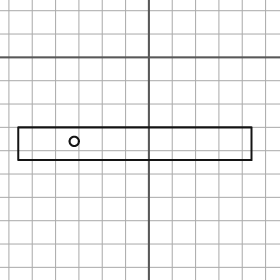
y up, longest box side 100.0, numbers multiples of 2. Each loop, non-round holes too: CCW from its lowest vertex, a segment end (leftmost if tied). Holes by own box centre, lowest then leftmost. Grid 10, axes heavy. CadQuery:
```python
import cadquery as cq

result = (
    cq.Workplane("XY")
    .moveTo(-56.0, -44.0)
    .lineTo(44.0, -44.0)
    .lineTo(44.0, -30.0)
    .lineTo(-56.0, -30.0)
    .close()
    .moveTo(-32.0, -36.0)
    .circle(2.0)
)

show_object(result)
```